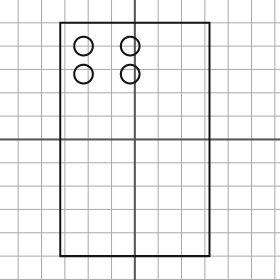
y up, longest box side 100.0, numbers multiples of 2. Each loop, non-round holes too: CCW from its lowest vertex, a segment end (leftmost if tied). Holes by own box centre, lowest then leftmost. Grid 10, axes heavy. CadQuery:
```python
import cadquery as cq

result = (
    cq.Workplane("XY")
    .moveTo(-32.0, -50.0)
    .lineTo(32.0, -50.0)
    .lineTo(32.0, 50.0)
    .lineTo(-32.0, 50.0)
    .close()
    .moveTo(-22.0, 28.0)
    .circle(4.0)
    .moveTo(-2.0, 28.0)
    .circle(4.0)
    .moveTo(-22.0, 40.0)
    .circle(4.0)
    .moveTo(-2.0, 40.0)
    .circle(4.0)
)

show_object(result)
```